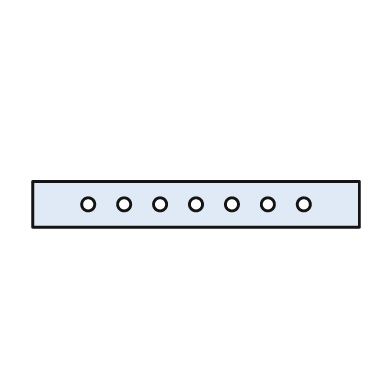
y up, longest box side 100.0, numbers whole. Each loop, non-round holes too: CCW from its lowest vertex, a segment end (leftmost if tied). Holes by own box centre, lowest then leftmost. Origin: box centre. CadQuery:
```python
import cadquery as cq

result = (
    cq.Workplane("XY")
    .moveTo(-50.0, -7.0)
    .lineTo(50.0, -7.0)
    .lineTo(50.0, 7.0)
    .lineTo(-50.0, 7.0)
    .close()
    .moveTo(-33.0, 0.0)
    .circle(2.0)
    .moveTo(-22.0, 0.0)
    .circle(2.0)
    .moveTo(-11.0, 0.0)
    .circle(2.0)
    .moveTo(0.0, 0.0)
    .circle(2.0)
    .moveTo(11.0, 0.0)
    .circle(2.0)
    .moveTo(22.0, 0.0)
    .circle(2.0)
    .moveTo(33.0, 0.0)
    .circle(2.0)
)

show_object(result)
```